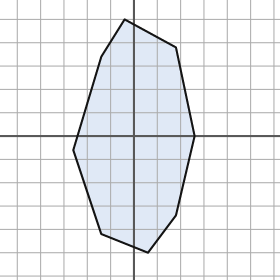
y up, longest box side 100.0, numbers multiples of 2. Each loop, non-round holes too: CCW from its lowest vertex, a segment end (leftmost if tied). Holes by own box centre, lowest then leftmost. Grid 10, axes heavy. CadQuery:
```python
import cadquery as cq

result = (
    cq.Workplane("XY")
    .moveTo(6.0, -50.0)
    .lineTo(18.0, -34.0)
    .lineTo(26.0, 0.0)
    .lineTo(18.0, 38.0)
    .lineTo(-4.0, 50.0)
    .lineTo(-14.0, 34.0)
    .lineTo(-26.0, -6.0)
    .lineTo(-14.0, -42.0)
    .close()
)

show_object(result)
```